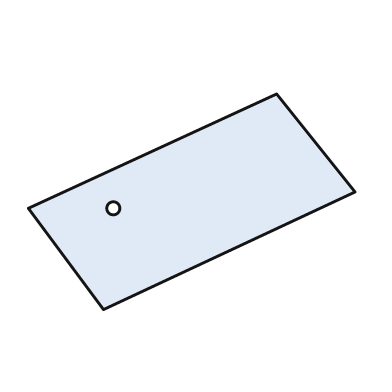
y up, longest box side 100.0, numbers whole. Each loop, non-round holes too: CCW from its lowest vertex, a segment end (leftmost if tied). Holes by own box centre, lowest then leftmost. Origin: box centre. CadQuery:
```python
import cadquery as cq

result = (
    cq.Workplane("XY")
    .moveTo(-27.0, -33.0)
    .lineTo(50.0, 3.0)
    .lineTo(26.0, 33.0)
    .lineTo(-50.0, -2.0)
    .close()
    .moveTo(-24.0, -2.0)
    .circle(2.0)
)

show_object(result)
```